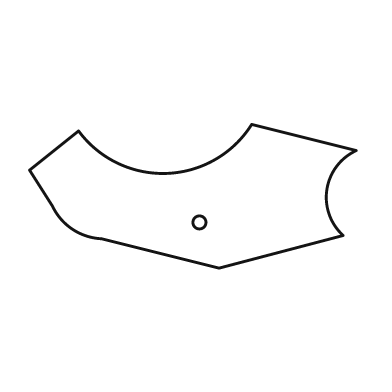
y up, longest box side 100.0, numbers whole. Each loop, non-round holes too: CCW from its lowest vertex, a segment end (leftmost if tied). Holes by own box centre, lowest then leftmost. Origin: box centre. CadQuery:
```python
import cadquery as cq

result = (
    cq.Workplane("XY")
    .moveTo(8.0, -22.0)
    .lineTo(46.0, -12.0)
    .threePointArc((41.0, 2.0), (50.0, 14.0))
    .lineTo(18.0, 22.0)
    .threePointArc((-8.0, 7.0), (-35.0, 20.0))
    .lineTo(-50.0, 8.0)
    .lineTo(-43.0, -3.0)
    .threePointArc((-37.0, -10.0), (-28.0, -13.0))
    .close()
    .moveTo(2.0, -8.0)
    .circle(2.0)
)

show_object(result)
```